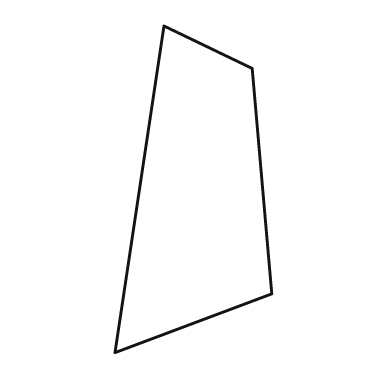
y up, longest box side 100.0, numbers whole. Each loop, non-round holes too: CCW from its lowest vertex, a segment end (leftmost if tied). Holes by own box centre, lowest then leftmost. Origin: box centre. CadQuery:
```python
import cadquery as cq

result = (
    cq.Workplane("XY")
    .moveTo(-24.0, -50.0)
    .lineTo(24.0, -32.0)
    .lineTo(18.0, 37.0)
    .lineTo(-9.0, 50.0)
    .close()
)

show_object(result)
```